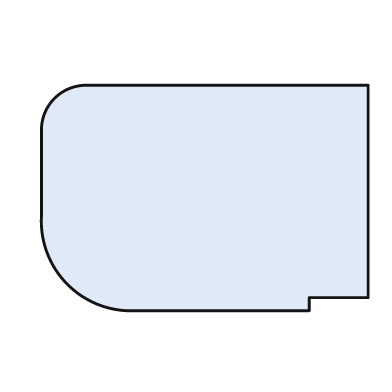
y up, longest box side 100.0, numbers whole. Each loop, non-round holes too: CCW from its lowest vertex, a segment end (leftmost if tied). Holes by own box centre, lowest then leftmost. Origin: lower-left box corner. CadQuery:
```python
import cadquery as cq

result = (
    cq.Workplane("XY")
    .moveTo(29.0, 0.0)
    .lineTo(82.0, 0.0)
    .lineTo(82.0, 4.0)
    .lineTo(100.0, 4.0)
    .lineTo(100.0, 69.0)
    .lineTo(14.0, 69.0)
    .threePointArc((4.0, 65.0), (0.0, 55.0))
    .lineTo(0.0, 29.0)
    .threePointArc((8.0, 8.0), (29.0, 0.0))
    .close()
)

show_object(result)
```